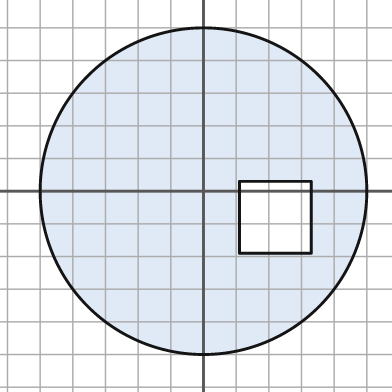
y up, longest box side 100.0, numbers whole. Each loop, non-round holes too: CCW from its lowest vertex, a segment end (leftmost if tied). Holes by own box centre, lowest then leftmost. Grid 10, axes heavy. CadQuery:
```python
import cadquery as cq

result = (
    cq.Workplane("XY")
    .moveTo(0.0, 0.0)
    .circle(50.0)
    .moveTo(11.0, -19.0)
    .lineTo(33.0, -19.0)
    .lineTo(33.0, 3.0)
    .lineTo(11.0, 3.0)
    .close()
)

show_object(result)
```